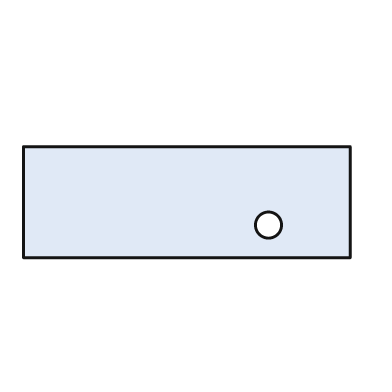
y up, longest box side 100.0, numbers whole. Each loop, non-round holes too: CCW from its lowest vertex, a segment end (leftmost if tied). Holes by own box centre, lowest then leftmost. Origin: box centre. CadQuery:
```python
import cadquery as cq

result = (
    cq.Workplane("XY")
    .moveTo(-50.0, -17.0)
    .lineTo(50.0, -17.0)
    .lineTo(50.0, 17.0)
    .lineTo(-50.0, 17.0)
    .close()
    .moveTo(25.0, -7.0)
    .circle(4.0)
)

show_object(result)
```